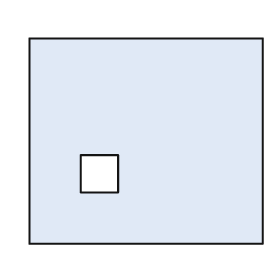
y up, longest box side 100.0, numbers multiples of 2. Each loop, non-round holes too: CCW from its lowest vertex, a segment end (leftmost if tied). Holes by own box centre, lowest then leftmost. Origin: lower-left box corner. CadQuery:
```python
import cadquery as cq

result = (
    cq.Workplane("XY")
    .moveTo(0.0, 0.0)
    .lineTo(100.0, 0.0)
    .lineTo(100.0, 88.0)
    .lineTo(0.0, 88.0)
    .close()
    .moveTo(22.0, 22.0)
    .lineTo(38.0, 22.0)
    .lineTo(38.0, 38.0)
    .lineTo(22.0, 38.0)
    .close()
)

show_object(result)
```